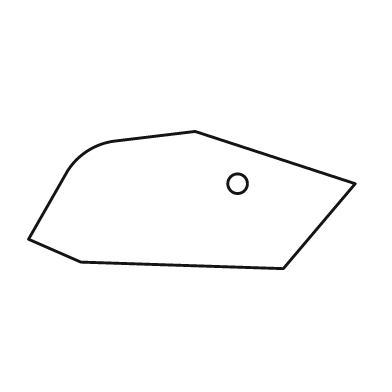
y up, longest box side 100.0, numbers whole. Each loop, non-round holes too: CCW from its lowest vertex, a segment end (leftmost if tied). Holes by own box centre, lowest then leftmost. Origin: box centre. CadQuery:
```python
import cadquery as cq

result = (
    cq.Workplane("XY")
    .moveTo(28.0, -21.0)
    .lineTo(50.0, 5.0)
    .lineTo(1.0, 21.0)
    .lineTo(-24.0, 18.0)
    .threePointArc((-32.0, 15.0), (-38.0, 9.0))
    .lineTo(-50.0, -12.0)
    .lineTo(-34.0, -19.0)
    .close()
    .moveTo(14.0, 5.0)
    .circle(3.0)
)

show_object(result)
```